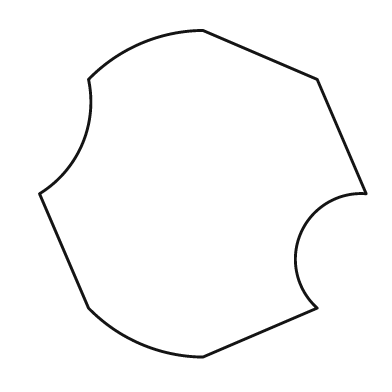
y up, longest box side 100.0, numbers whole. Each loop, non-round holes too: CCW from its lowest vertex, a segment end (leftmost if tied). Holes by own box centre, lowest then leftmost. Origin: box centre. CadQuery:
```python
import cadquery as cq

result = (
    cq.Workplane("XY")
    .moveTo(0.0, -50.0)
    .lineTo(35.0, -35.0)
    .threePointArc((30.0, -12.0), (50.0, 0.0))
    .lineTo(35.0, 35.0)
    .lineTo(0.0, 50.0)
    .threePointArc((-19.0, 46.0), (-35.0, 35.0))
    .threePointArc((-37.0, 15.0), (-50.0, 0.0))
    .lineTo(-35.0, -35.0)
    .threePointArc((-19.0, -46.0), (0.0, -50.0))
    .close()
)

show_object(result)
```